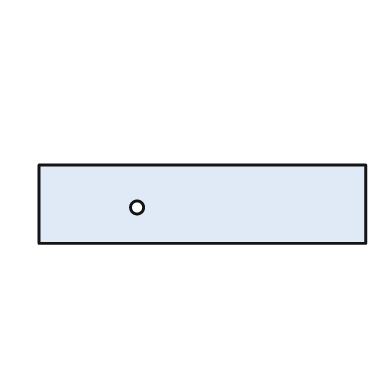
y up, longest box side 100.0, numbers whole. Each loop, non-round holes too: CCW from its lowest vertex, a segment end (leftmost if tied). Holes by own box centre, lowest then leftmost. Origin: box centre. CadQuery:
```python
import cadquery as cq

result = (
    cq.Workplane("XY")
    .moveTo(-50.0, -12.0)
    .lineTo(50.0, -12.0)
    .lineTo(50.0, 12.0)
    .lineTo(-50.0, 12.0)
    .close()
    .moveTo(-20.0, -1.0)
    .circle(2.0)
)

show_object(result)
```